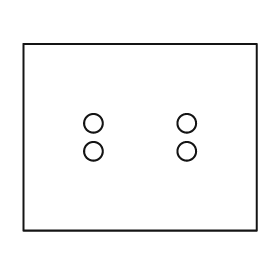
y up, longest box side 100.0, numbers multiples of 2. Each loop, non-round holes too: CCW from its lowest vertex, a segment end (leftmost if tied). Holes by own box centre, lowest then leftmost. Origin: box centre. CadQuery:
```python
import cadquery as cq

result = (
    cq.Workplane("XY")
    .moveTo(-50.0, -40.0)
    .lineTo(50.0, -40.0)
    .lineTo(50.0, 40.0)
    .lineTo(-50.0, 40.0)
    .close()
    .moveTo(-20.0, -6.0)
    .circle(4.0)
    .moveTo(20.0, -6.0)
    .circle(4.0)
    .moveTo(-20.0, 6.0)
    .circle(4.0)
    .moveTo(20.0, 6.0)
    .circle(4.0)
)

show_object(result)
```